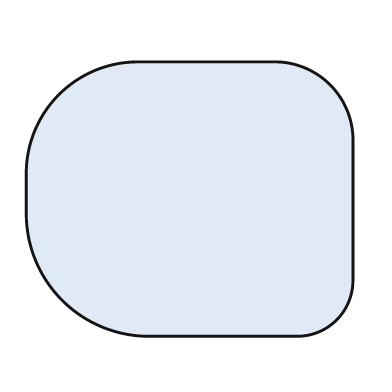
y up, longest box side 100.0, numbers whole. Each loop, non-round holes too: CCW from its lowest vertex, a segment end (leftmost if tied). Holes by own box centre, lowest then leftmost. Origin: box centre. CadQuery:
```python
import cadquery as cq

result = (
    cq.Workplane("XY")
    .moveTo(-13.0, -42.0)
    .lineTo(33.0, -42.0)
    .threePointArc((45.0, -37.0), (50.0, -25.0))
    .lineTo(50.0, 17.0)
    .threePointArc((43.0, 35.0), (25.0, 42.0))
    .lineTo(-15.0, 42.0)
    .threePointArc((-40.0, 32.0), (-50.0, 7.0))
    .lineTo(-50.0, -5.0)
    .threePointArc((-39.0, -31.0), (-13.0, -42.0))
    .close()
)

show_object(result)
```